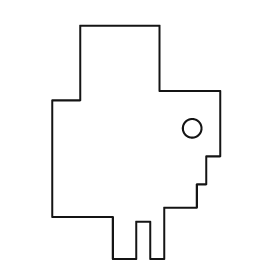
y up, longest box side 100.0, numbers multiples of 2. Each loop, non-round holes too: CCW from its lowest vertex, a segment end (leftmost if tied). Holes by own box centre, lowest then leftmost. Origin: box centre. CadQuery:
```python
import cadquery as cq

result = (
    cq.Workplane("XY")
    .moveTo(-10.0, -50.0)
    .lineTo(0.0, -50.0)
    .lineTo(0.0, -34.0)
    .lineTo(6.0, -34.0)
    .lineTo(6.0, -50.0)
    .lineTo(12.0, -50.0)
    .lineTo(12.0, -28.0)
    .lineTo(26.0, -28.0)
    .lineTo(26.0, -18.0)
    .lineTo(30.0, -18.0)
    .lineTo(30.0, -6.0)
    .lineTo(36.0, -6.0)
    .lineTo(36.0, 22.0)
    .lineTo(10.0, 22.0)
    .lineTo(10.0, 50.0)
    .lineTo(-24.0, 50.0)
    .lineTo(-24.0, 18.0)
    .lineTo(-36.0, 18.0)
    .lineTo(-36.0, -32.0)
    .lineTo(-10.0, -32.0)
    .close()
    .moveTo(24.0, 6.0)
    .circle(4.0)
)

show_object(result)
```